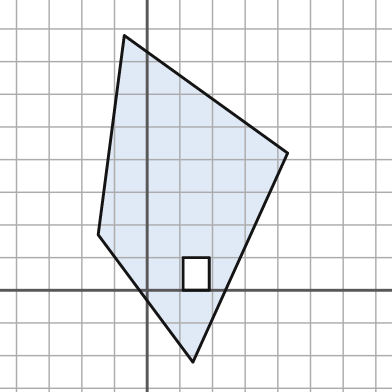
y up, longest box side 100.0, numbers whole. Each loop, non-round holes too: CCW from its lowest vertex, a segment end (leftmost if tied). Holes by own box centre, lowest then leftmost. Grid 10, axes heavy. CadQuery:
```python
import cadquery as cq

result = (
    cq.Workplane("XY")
    .moveTo(14.0, -22.0)
    .lineTo(43.0, 42.0)
    .lineTo(-7.0, 78.0)
    .lineTo(-15.0, 17.0)
    .close()
    .moveTo(11.0, 0.0)
    .lineTo(19.0, 0.0)
    .lineTo(19.0, 10.0)
    .lineTo(11.0, 10.0)
    .close()
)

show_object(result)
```